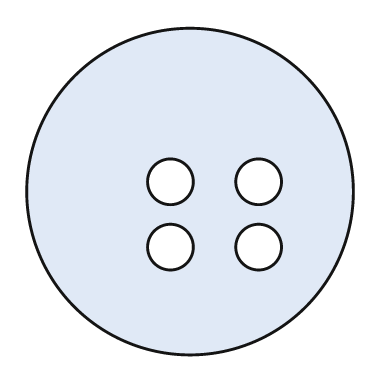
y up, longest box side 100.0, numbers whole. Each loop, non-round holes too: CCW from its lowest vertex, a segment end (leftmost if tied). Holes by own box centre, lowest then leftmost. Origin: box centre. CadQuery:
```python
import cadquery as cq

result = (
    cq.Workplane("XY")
    .moveTo(0.0, 0.0)
    .circle(50.0)
    .moveTo(-6.0, -17.0)
    .circle(7.0)
    .moveTo(21.0, -17.0)
    .circle(7.0)
    .moveTo(-6.0, 3.0)
    .circle(7.0)
    .moveTo(21.0, 3.0)
    .circle(7.0)
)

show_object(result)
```